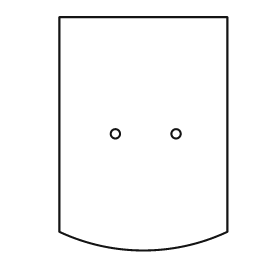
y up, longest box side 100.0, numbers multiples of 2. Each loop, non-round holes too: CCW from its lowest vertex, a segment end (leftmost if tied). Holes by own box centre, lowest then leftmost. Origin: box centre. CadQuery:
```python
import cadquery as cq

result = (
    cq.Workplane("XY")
    .moveTo(-36.0, -42.0)
    .threePointArc((0.0, -50.0), (36.0, -42.0))
    .lineTo(36.0, 50.0)
    .lineTo(-36.0, 50.0)
    .close()
    .moveTo(-12.0, 0.0)
    .circle(2.0)
    .moveTo(14.0, 0.0)
    .circle(2.0)
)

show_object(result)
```